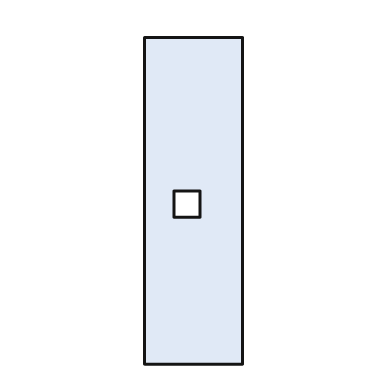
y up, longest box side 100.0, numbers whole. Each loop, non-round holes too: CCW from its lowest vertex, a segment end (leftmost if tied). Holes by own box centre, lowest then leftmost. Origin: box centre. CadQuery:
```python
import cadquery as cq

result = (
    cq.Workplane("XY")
    .moveTo(-15.0, -50.0)
    .lineTo(15.0, -50.0)
    .lineTo(15.0, 50.0)
    .lineTo(-15.0, 50.0)
    .close()
    .moveTo(-6.0, -5.0)
    .lineTo(2.0, -5.0)
    .lineTo(2.0, 3.0)
    .lineTo(-6.0, 3.0)
    .close()
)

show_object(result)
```